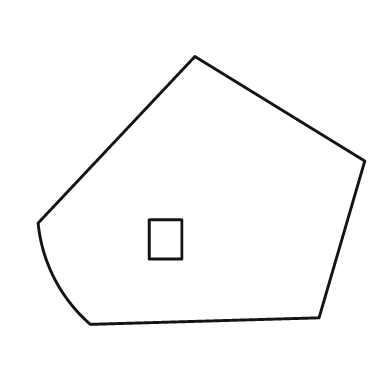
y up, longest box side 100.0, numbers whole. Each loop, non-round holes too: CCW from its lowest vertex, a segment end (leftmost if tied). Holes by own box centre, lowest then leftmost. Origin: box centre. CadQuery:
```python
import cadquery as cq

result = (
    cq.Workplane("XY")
    .moveTo(-34.0, -41.0)
    .lineTo(36.0, -39.0)
    .lineTo(50.0, 9.0)
    .lineTo(-2.0, 41.0)
    .lineTo(-50.0, -10.0)
    .threePointArc((-45.0, -27.0), (-34.0, -41.0))
    .close()
    .moveTo(-16.0, -21.0)
    .lineTo(-6.0, -21.0)
    .lineTo(-6.0, -9.0)
    .lineTo(-16.0, -9.0)
    .close()
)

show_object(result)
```